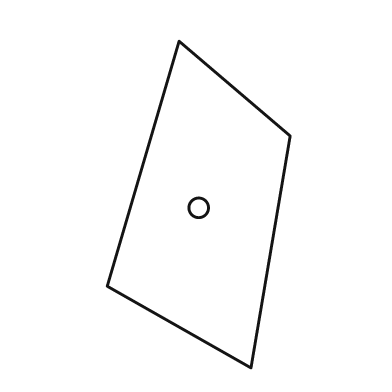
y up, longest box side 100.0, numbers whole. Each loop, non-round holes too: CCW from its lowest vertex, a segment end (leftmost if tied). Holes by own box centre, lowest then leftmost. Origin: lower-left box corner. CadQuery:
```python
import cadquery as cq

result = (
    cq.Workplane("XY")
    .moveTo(44.0, 0.0)
    .lineTo(56.0, 71.0)
    .lineTo(22.0, 100.0)
    .lineTo(0.0, 25.0)
    .close()
    .moveTo(28.0, 49.0)
    .circle(3.0)
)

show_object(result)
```